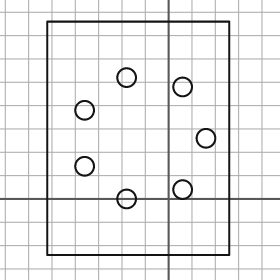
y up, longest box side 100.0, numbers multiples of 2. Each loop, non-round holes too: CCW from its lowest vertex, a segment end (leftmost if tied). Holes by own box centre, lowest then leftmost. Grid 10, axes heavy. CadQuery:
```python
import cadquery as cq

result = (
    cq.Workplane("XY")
    .moveTo(-52.0, -24.0)
    .lineTo(26.0, -24.0)
    .lineTo(26.0, 76.0)
    .lineTo(-52.0, 76.0)
    .close()
    .moveTo(-18.0, 0.0)
    .circle(4.0)
    .moveTo(6.0, 4.0)
    .circle(4.0)
    .moveTo(-36.0, 14.0)
    .circle(4.0)
    .moveTo(16.0, 26.0)
    .circle(4.0)
    .moveTo(-36.0, 38.0)
    .circle(4.0)
    .moveTo(6.0, 48.0)
    .circle(4.0)
    .moveTo(-18.0, 52.0)
    .circle(4.0)
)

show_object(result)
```